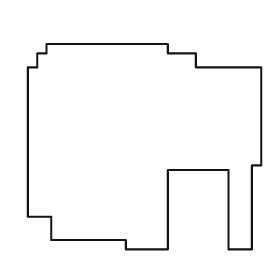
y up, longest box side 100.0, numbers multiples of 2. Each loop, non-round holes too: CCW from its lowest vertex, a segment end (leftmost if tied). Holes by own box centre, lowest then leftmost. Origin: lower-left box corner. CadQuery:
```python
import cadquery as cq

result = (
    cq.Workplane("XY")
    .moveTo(42.0, 0.0)
    .lineTo(60.0, 0.0)
    .lineTo(60.0, 34.0)
    .lineTo(86.0, 34.0)
    .lineTo(86.0, 0.0)
    .lineTo(96.0, 0.0)
    .lineTo(96.0, 36.0)
    .lineTo(100.0, 36.0)
    .lineTo(100.0, 78.0)
    .lineTo(72.0, 78.0)
    .lineTo(72.0, 84.0)
    .lineTo(60.0, 84.0)
    .lineTo(60.0, 88.0)
    .lineTo(8.0, 88.0)
    .lineTo(8.0, 84.0)
    .lineTo(4.0, 84.0)
    .lineTo(4.0, 78.0)
    .lineTo(0.0, 78.0)
    .lineTo(0.0, 14.0)
    .lineTo(10.0, 14.0)
    .lineTo(10.0, 4.0)
    .lineTo(42.0, 4.0)
    .close()
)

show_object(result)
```